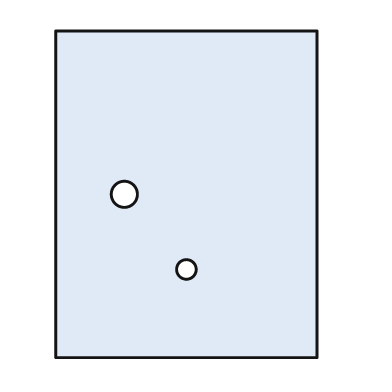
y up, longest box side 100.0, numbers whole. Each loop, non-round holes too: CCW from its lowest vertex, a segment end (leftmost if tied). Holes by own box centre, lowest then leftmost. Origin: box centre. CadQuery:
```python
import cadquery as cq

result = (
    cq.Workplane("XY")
    .moveTo(-40.0, -50.0)
    .lineTo(40.0, -50.0)
    .lineTo(40.0, 50.0)
    .lineTo(-40.0, 50.0)
    .close()
    .moveTo(0.0, -23.0)
    .circle(3.0)
    .moveTo(-19.0, 0.0)
    .circle(4.0)
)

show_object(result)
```